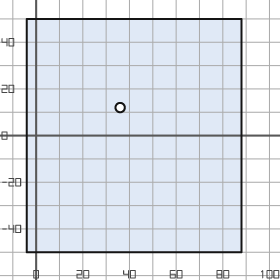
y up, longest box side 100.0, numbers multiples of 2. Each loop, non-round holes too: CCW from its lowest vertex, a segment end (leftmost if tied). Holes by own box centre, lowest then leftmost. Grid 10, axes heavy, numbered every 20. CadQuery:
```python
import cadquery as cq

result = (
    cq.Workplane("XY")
    .moveTo(-4.0, -50.0)
    .lineTo(88.0, -50.0)
    .lineTo(88.0, 50.0)
    .lineTo(-4.0, 50.0)
    .close()
    .moveTo(36.0, 12.0)
    .circle(2.0)
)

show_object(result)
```